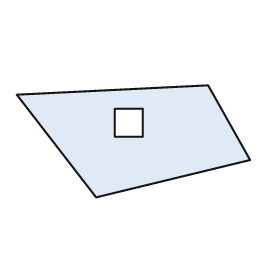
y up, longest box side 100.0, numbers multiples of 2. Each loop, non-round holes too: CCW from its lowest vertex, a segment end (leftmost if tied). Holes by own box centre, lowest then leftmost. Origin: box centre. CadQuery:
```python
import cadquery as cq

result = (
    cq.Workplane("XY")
    .moveTo(-16.0, -24.0)
    .lineTo(50.0, -8.0)
    .lineTo(32.0, 24.0)
    .lineTo(-50.0, 20.0)
    .close()
    .moveTo(-8.0, 2.0)
    .lineTo(4.0, 2.0)
    .lineTo(4.0, 14.0)
    .lineTo(-8.0, 14.0)
    .close()
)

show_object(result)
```